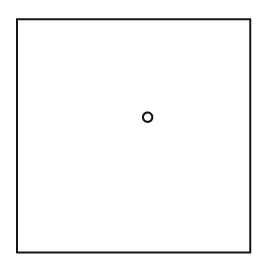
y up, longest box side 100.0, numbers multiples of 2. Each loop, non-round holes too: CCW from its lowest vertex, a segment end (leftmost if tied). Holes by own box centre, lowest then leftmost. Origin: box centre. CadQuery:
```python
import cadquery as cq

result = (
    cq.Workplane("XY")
    .moveTo(-50.0, -50.0)
    .lineTo(50.0, -50.0)
    .lineTo(50.0, 50.0)
    .lineTo(-50.0, 50.0)
    .close()
    .moveTo(6.0, 8.0)
    .circle(2.0)
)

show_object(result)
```